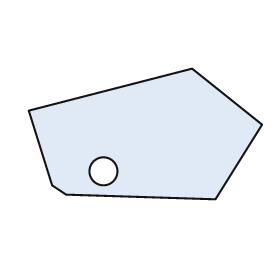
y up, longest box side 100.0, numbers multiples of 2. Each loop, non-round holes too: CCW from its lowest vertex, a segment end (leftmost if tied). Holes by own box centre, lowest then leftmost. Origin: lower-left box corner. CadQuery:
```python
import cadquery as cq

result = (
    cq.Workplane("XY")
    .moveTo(80.0, 0.0)
    .lineTo(100.0, 32.0)
    .lineTo(70.0, 56.0)
    .lineTo(0.0, 38.0)
    .lineTo(10.0, 6.0)
    .lineTo(16.0, 2.0)
    .close()
    .moveTo(32.0, 12.0)
    .circle(6.0)
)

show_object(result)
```